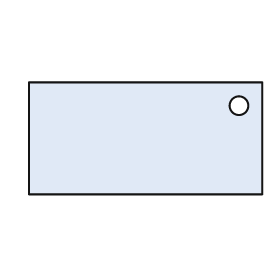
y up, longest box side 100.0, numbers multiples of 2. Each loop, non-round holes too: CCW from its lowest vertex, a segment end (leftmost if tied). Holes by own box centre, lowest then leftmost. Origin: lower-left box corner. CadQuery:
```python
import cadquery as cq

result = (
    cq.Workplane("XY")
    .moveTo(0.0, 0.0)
    .lineTo(100.0, 0.0)
    .lineTo(100.0, 48.0)
    .lineTo(0.0, 48.0)
    .close()
    .moveTo(90.0, 38.0)
    .circle(4.0)
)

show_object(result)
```